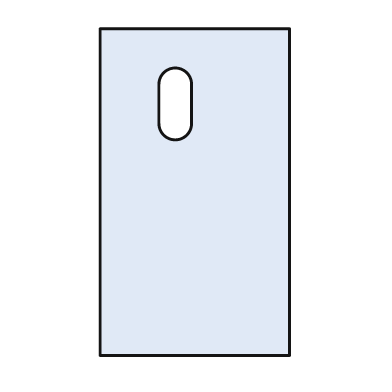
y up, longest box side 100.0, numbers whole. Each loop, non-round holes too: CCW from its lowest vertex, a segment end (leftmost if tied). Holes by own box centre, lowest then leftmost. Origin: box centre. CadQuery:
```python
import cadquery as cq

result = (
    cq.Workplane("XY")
    .moveTo(-29.0, -50.0)
    .lineTo(29.0, -50.0)
    .lineTo(29.0, 50.0)
    .lineTo(-29.0, 50.0)
    .close()
    .moveTo(-11.0, 21.0)
    .threePointArc((-6.0, 16.0), (-1.0, 21.0))
    .lineTo(-1.0, 33.0)
    .threePointArc((-6.0, 38.0), (-11.0, 33.0))
    .close()
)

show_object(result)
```